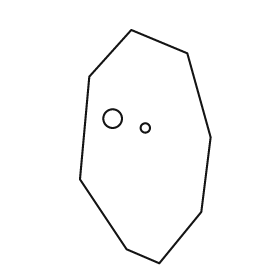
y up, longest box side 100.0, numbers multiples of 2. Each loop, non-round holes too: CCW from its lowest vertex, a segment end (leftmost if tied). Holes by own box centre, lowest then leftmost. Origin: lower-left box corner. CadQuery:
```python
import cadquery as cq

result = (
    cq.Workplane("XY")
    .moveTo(34.0, 0.0)
    .lineTo(52.0, 22.0)
    .lineTo(56.0, 54.0)
    .lineTo(46.0, 90.0)
    .lineTo(22.0, 100.0)
    .lineTo(4.0, 80.0)
    .lineTo(0.0, 36.0)
    .lineTo(20.0, 6.0)
    .close()
    .moveTo(28.0, 58.0)
    .circle(2.0)
    .moveTo(14.0, 62.0)
    .circle(4.0)
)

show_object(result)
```